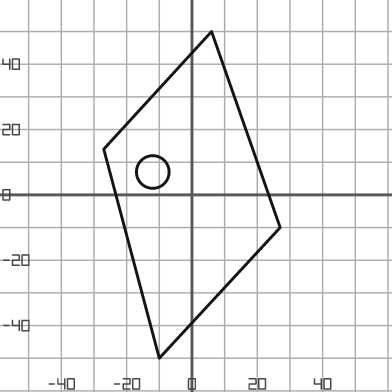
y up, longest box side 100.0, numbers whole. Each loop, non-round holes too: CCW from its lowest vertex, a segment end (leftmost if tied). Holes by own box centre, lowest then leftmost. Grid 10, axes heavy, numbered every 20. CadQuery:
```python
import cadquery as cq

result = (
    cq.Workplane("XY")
    .moveTo(-10.0, -50.0)
    .lineTo(27.0, -10.0)
    .lineTo(6.0, 50.0)
    .lineTo(-27.0, 14.0)
    .close()
    .moveTo(-12.0, 7.0)
    .circle(5.0)
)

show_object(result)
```